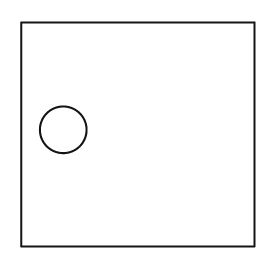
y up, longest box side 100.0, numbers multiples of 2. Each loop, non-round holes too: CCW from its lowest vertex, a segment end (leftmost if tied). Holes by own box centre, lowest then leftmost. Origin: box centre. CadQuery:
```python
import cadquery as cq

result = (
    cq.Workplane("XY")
    .moveTo(-50.0, -48.0)
    .lineTo(50.0, -48.0)
    .lineTo(50.0, 48.0)
    .lineTo(-50.0, 48.0)
    .close()
    .moveTo(-32.0, 2.0)
    .circle(10.0)
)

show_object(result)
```